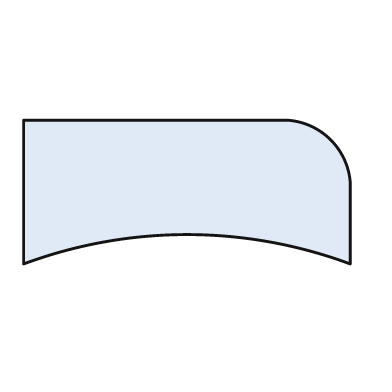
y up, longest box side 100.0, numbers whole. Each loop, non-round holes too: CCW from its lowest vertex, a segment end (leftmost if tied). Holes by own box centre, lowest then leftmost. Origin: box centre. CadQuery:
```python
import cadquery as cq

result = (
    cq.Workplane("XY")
    .moveTo(-50.0, -22.0)
    .threePointArc((0.0, -13.0), (50.0, -22.0))
    .lineTo(50.0, 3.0)
    .threePointArc((44.0, 16.0), (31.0, 22.0))
    .lineTo(-50.0, 22.0)
    .close()
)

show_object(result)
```